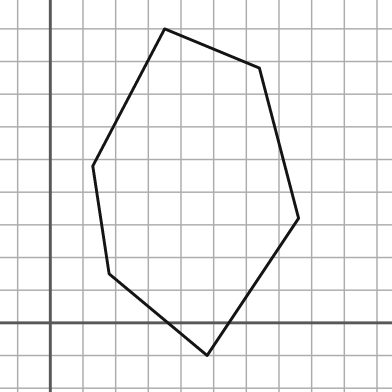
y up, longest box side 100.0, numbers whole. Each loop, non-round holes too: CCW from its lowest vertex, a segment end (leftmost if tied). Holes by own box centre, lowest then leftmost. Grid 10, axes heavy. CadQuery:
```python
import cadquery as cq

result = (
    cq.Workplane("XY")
    .moveTo(48.0, -10.0)
    .lineTo(76.0, 32.0)
    .lineTo(64.0, 78.0)
    .lineTo(35.0, 90.0)
    .lineTo(13.0, 48.0)
    .lineTo(18.0, 15.0)
    .close()
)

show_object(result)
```